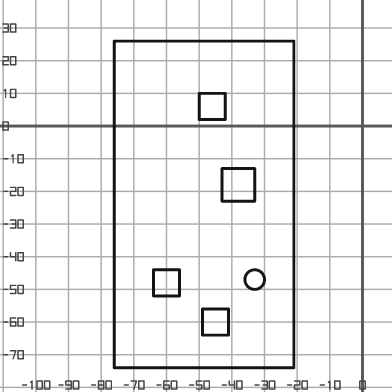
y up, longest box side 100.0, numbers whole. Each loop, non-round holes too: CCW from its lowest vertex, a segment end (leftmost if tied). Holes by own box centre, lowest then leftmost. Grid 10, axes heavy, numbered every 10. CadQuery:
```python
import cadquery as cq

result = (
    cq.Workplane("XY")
    .moveTo(-76.0, -74.0)
    .lineTo(-21.0, -74.0)
    .lineTo(-21.0, 26.0)
    .lineTo(-76.0, 26.0)
    .close()
    .moveTo(-49.0, -64.0)
    .lineTo(-41.0, -64.0)
    .lineTo(-41.0, -56.0)
    .lineTo(-49.0, -56.0)
    .close()
    .moveTo(-64.0, -52.0)
    .lineTo(-56.0, -52.0)
    .lineTo(-56.0, -44.0)
    .lineTo(-64.0, -44.0)
    .close()
    .moveTo(-33.0, -47.0)
    .circle(3.0)
    .moveTo(-43.0, -23.0)
    .lineTo(-33.0, -23.0)
    .lineTo(-33.0, -13.0)
    .lineTo(-43.0, -13.0)
    .close()
    .moveTo(-50.0, 2.0)
    .lineTo(-42.0, 2.0)
    .lineTo(-42.0, 10.0)
    .lineTo(-50.0, 10.0)
    .close()
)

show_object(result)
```